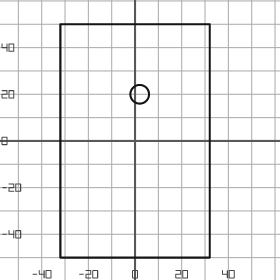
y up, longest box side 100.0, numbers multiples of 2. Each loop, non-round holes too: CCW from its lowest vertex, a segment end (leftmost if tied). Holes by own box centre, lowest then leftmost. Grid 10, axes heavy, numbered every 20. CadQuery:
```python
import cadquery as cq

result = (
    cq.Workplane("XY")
    .moveTo(-32.0, -50.0)
    .lineTo(32.0, -50.0)
    .lineTo(32.0, 50.0)
    .lineTo(-32.0, 50.0)
    .close()
    .moveTo(2.0, 20.0)
    .circle(4.0)
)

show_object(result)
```